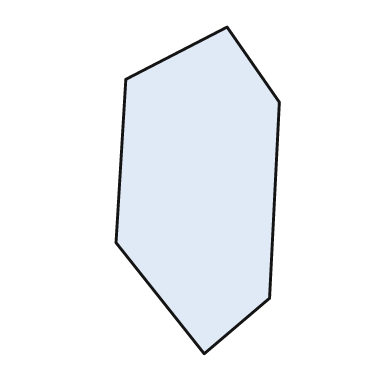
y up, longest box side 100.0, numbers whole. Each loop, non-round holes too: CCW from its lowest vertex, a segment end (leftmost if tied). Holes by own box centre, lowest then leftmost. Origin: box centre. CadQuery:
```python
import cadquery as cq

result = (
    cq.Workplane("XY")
    .moveTo(2.0, -50.0)
    .lineTo(22.0, -33.0)
    .lineTo(25.0, 27.0)
    .lineTo(9.0, 50.0)
    .lineTo(-22.0, 34.0)
    .lineTo(-25.0, -16.0)
    .close()
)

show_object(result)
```